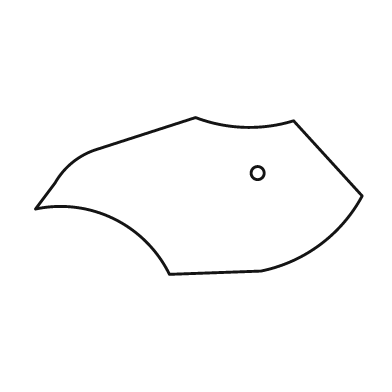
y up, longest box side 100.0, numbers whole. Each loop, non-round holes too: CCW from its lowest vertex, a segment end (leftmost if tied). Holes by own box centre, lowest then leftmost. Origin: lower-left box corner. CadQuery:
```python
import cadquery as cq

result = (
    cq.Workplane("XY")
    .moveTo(41.0, 0.0)
    .lineTo(69.0, 1.0)
    .threePointArc((87.0, 9.0), (100.0, 24.0))
    .lineTo(79.0, 47.0)
    .threePointArc((64.0, 45.0), (49.0, 48.0))
    .lineTo(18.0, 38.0)
    .threePointArc((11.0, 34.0), (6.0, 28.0))
    .lineTo(0.0, 20.0)
    .threePointArc((24.0, 17.0), (41.0, 0.0))
    .close()
    .moveTo(68.0, 31.0)
    .circle(2.0)
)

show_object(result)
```